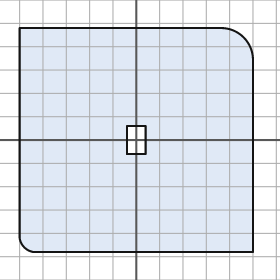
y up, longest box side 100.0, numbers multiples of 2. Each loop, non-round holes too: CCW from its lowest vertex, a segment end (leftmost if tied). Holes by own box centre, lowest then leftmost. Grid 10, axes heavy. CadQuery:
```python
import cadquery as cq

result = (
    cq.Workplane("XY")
    .moveTo(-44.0, -48.0)
    .lineTo(50.0, -48.0)
    .lineTo(50.0, 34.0)
    .threePointArc((46.0, 44.0), (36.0, 48.0))
    .lineTo(-50.0, 48.0)
    .lineTo(-50.0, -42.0)
    .threePointArc((-48.0, -46.0), (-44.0, -48.0))
    .close()
    .moveTo(-4.0, -6.0)
    .lineTo(4.0, -6.0)
    .lineTo(4.0, 6.0)
    .lineTo(-4.0, 6.0)
    .close()
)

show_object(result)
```